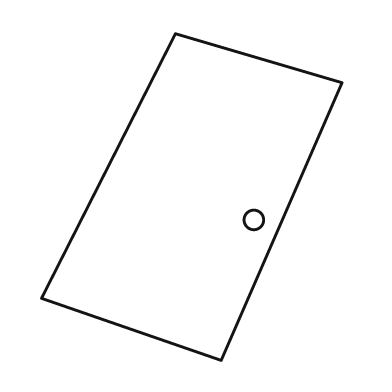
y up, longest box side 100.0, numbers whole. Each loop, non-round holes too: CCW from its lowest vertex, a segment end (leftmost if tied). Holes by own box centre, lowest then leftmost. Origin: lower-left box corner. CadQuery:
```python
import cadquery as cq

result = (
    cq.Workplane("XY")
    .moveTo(55.0, 0.0)
    .lineTo(92.0, 85.0)
    .lineTo(41.0, 100.0)
    .lineTo(0.0, 19.0)
    .close()
    .moveTo(65.0, 43.0)
    .circle(3.0)
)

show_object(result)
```